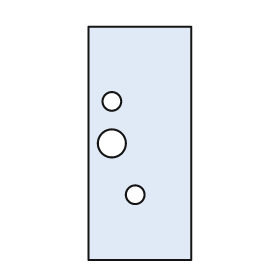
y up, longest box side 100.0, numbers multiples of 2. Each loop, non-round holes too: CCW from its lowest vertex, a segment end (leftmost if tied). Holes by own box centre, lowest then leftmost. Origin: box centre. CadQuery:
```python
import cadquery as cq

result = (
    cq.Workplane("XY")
    .moveTo(-22.0, -50.0)
    .lineTo(22.0, -50.0)
    .lineTo(22.0, 50.0)
    .lineTo(-22.0, 50.0)
    .close()
    .moveTo(-2.0, -22.0)
    .circle(4.0)
    .moveTo(-12.0, 0.0)
    .circle(6.0)
    .moveTo(-12.0, 18.0)
    .circle(4.0)
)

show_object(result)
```